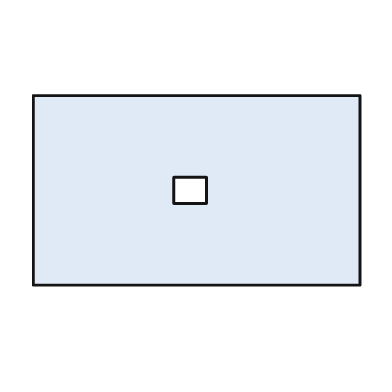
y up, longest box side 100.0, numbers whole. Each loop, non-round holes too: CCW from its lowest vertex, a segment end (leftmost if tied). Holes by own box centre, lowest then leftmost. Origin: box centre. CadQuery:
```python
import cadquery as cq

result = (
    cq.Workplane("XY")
    .moveTo(-50.0, -29.0)
    .lineTo(50.0, -29.0)
    .lineTo(50.0, 29.0)
    .lineTo(-50.0, 29.0)
    .close()
    .moveTo(-7.0, -4.0)
    .lineTo(3.0, -4.0)
    .lineTo(3.0, 4.0)
    .lineTo(-7.0, 4.0)
    .close()
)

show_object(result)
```